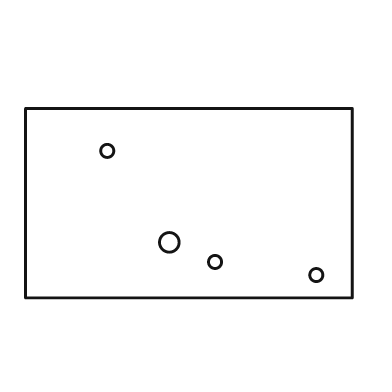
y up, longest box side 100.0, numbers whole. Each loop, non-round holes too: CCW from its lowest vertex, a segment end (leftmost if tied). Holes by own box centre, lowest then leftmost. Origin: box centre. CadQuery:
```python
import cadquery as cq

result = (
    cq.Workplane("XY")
    .moveTo(-50.0, -29.0)
    .lineTo(50.0, -29.0)
    .lineTo(50.0, 29.0)
    .lineTo(-50.0, 29.0)
    .close()
    .moveTo(39.0, -22.0)
    .circle(2.0)
    .moveTo(8.0, -18.0)
    .circle(2.0)
    .moveTo(-6.0, -12.0)
    .circle(3.0)
    .moveTo(-25.0, 16.0)
    .circle(2.0)
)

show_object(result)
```